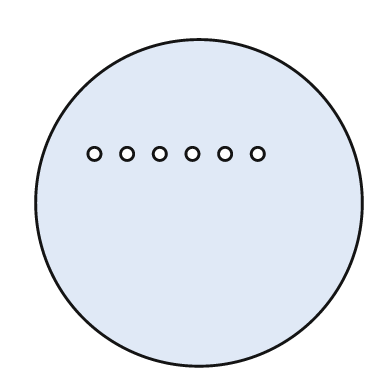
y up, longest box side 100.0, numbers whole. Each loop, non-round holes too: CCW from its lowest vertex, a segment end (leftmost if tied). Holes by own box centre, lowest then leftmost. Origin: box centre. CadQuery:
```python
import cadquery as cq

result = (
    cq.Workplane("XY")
    .moveTo(0.0, 0.0)
    .circle(50.0)
    .moveTo(-32.0, 15.0)
    .circle(2.0)
    .moveTo(-22.0, 15.0)
    .circle(2.0)
    .moveTo(-12.0, 15.0)
    .circle(2.0)
    .moveTo(-2.0, 15.0)
    .circle(2.0)
    .moveTo(8.0, 15.0)
    .circle(2.0)
    .moveTo(18.0, 15.0)
    .circle(2.0)
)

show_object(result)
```